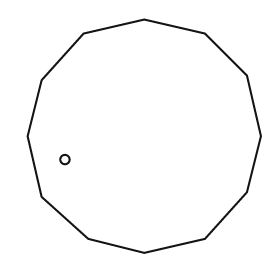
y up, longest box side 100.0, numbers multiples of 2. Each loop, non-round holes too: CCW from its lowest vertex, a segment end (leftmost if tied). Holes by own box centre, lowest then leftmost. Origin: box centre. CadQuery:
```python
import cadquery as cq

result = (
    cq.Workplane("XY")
    .moveTo(0.0, -50.0)
    .lineTo(26.0, -44.0)
    .lineTo(44.0, -24.0)
    .lineTo(50.0, 0.0)
    .lineTo(44.0, 26.0)
    .lineTo(26.0, 44.0)
    .lineTo(0.0, 50.0)
    .lineTo(-26.0, 44.0)
    .lineTo(-44.0, 24.0)
    .lineTo(-50.0, 0.0)
    .lineTo(-44.0, -26.0)
    .lineTo(-24.0, -44.0)
    .close()
    .moveTo(-34.0, -10.0)
    .circle(2.0)
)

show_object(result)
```